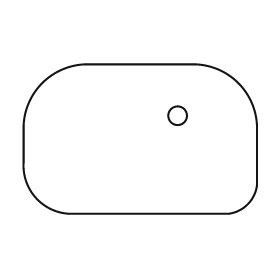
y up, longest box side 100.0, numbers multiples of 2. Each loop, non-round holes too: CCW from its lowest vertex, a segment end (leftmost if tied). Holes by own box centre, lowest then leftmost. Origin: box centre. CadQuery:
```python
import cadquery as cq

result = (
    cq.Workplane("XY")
    .moveTo(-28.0, -32.0)
    .lineTo(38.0, -32.0)
    .threePointArc((46.0, -28.0), (50.0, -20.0))
    .lineTo(50.0, 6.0)
    .threePointArc((42.0, 24.0), (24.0, 32.0))
    .lineTo(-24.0, 32.0)
    .threePointArc((-42.0, 24.0), (-50.0, 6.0))
    .lineTo(-50.0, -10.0)
    .threePointArc((-44.0, -26.0), (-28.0, -32.0))
    .close()
    .moveTo(16.0, 10.0)
    .circle(4.0)
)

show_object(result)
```